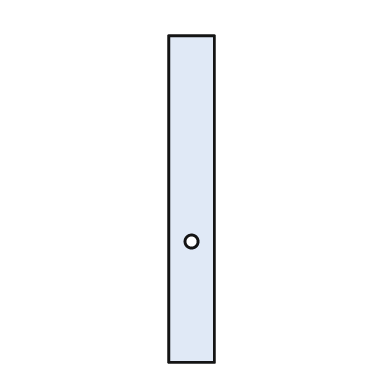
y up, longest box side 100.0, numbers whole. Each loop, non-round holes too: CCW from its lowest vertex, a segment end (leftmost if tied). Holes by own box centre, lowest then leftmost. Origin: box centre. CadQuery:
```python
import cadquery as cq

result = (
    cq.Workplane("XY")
    .moveTo(-7.0, -50.0)
    .lineTo(7.0, -50.0)
    .lineTo(7.0, 50.0)
    .lineTo(-7.0, 50.0)
    .close()
    .moveTo(0.0, -13.0)
    .circle(2.0)
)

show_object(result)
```